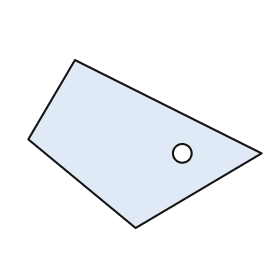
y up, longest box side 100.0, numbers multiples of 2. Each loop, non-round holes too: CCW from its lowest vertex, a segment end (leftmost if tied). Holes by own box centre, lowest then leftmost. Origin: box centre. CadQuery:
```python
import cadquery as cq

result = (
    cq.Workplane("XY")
    .moveTo(-4.0, -36.0)
    .lineTo(50.0, -4.0)
    .lineTo(-30.0, 36.0)
    .lineTo(-50.0, 2.0)
    .close()
    .moveTo(16.0, -4.0)
    .circle(4.0)
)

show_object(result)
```